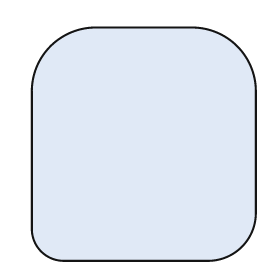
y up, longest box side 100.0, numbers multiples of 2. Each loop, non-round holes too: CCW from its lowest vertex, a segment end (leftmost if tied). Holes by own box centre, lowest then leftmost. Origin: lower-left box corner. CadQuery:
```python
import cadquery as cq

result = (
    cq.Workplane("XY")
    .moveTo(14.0, 0.0)
    .lineTo(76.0, 0.0)
    .threePointArc((90.0, 6.0), (96.0, 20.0))
    .lineTo(96.0, 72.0)
    .threePointArc((88.0, 92.0), (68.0, 100.0))
    .lineTo(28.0, 100.0)
    .threePointArc((8.0, 92.0), (0.0, 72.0))
    .lineTo(0.0, 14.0)
    .threePointArc((4.0, 4.0), (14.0, 0.0))
    .close()
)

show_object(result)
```